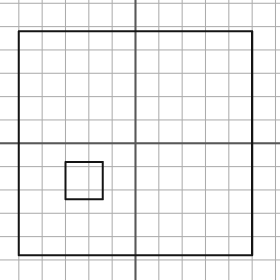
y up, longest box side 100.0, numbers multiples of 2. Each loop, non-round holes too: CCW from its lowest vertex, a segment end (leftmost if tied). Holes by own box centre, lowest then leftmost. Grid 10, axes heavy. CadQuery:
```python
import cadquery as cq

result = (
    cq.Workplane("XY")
    .moveTo(-50.0, -48.0)
    .lineTo(50.0, -48.0)
    .lineTo(50.0, 48.0)
    .lineTo(-50.0, 48.0)
    .close()
    .moveTo(-30.0, -24.0)
    .lineTo(-14.0, -24.0)
    .lineTo(-14.0, -8.0)
    .lineTo(-30.0, -8.0)
    .close()
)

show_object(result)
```